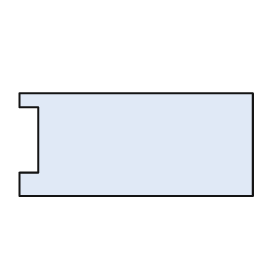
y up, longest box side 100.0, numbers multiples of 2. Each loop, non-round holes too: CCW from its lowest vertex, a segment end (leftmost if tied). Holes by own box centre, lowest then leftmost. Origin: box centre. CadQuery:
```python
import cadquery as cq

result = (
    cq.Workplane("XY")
    .moveTo(-50.0, -22.0)
    .lineTo(50.0, -22.0)
    .lineTo(50.0, 22.0)
    .lineTo(-50.0, 22.0)
    .lineTo(-50.0, 16.0)
    .lineTo(-42.0, 16.0)
    .lineTo(-42.0, -12.0)
    .lineTo(-50.0, -12.0)
    .close()
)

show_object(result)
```